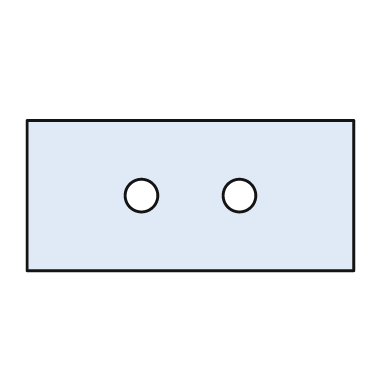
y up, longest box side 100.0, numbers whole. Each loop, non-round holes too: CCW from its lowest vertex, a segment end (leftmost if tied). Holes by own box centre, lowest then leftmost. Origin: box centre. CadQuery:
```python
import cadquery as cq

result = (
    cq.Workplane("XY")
    .moveTo(-50.0, -23.0)
    .lineTo(50.0, -23.0)
    .lineTo(50.0, 23.0)
    .lineTo(-50.0, 23.0)
    .close()
    .moveTo(-15.0, 0.0)
    .circle(5.0)
    .moveTo(15.0, 0.0)
    .circle(5.0)
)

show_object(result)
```